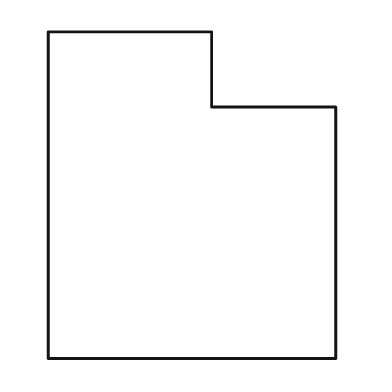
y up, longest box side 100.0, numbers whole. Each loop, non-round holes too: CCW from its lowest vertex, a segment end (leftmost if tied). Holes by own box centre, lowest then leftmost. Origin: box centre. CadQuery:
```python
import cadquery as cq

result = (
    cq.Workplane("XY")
    .moveTo(-44.0, -50.0)
    .lineTo(44.0, -50.0)
    .lineTo(44.0, 27.0)
    .lineTo(6.0, 27.0)
    .lineTo(6.0, 50.0)
    .lineTo(-44.0, 50.0)
    .close()
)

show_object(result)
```